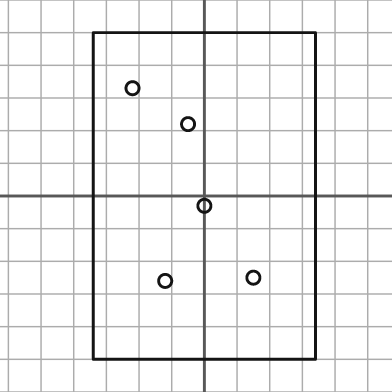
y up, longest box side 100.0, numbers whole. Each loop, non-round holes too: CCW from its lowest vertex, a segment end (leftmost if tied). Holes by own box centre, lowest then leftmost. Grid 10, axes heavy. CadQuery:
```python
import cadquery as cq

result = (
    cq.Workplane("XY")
    .moveTo(-34.0, -50.0)
    .lineTo(34.0, -50.0)
    .lineTo(34.0, 50.0)
    .lineTo(-34.0, 50.0)
    .close()
    .moveTo(-12.0, -26.0)
    .circle(2.0)
    .moveTo(15.0, -25.0)
    .circle(2.0)
    .moveTo(0.0, -3.0)
    .circle(2.0)
    .moveTo(-5.0, 22.0)
    .circle(2.0)
    .moveTo(-22.0, 33.0)
    .circle(2.0)
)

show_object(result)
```